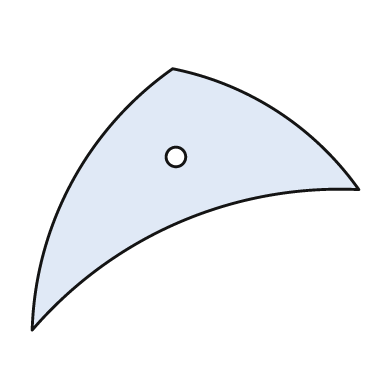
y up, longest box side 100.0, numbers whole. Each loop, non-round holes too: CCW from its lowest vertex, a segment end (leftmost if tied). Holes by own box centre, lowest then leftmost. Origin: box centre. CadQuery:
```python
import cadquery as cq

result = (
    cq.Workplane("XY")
    .moveTo(-50.0, -40.0)
    .threePointArc((-5.0, -7.0), (50.0, 3.0))
    .threePointArc((25.0, 27.0), (-7.0, 40.0))
    .threePointArc((-38.0, 5.0), (-50.0, -40.0))
    .close()
    .moveTo(-6.0, 13.0)
    .circle(3.0)
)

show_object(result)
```